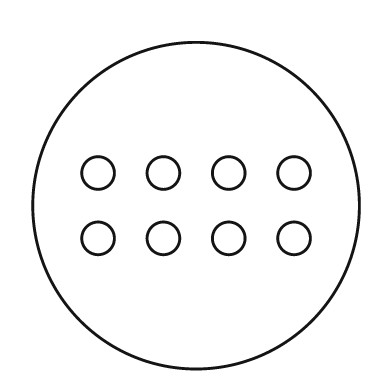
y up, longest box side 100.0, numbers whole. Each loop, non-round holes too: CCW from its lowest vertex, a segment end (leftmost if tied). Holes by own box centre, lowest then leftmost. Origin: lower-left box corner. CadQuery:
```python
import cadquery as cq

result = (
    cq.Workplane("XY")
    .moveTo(50.0, 50.0)
    .circle(50.0)
    .moveTo(20.0, 40.0)
    .circle(5.0)
    .moveTo(40.0, 40.0)
    .circle(5.0)
    .moveTo(60.0, 40.0)
    .circle(5.0)
    .moveTo(80.0, 40.0)
    .circle(5.0)
    .moveTo(20.0, 60.0)
    .circle(5.0)
    .moveTo(40.0, 60.0)
    .circle(5.0)
    .moveTo(60.0, 60.0)
    .circle(5.0)
    .moveTo(80.0, 60.0)
    .circle(5.0)
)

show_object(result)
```